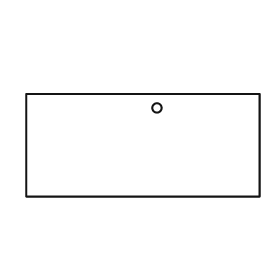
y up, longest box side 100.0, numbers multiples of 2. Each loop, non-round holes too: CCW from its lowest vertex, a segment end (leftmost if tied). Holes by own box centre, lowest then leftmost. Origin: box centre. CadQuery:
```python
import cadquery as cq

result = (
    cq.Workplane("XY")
    .moveTo(-50.0, -22.0)
    .lineTo(50.0, -22.0)
    .lineTo(50.0, 22.0)
    .lineTo(-50.0, 22.0)
    .close()
    .moveTo(6.0, 16.0)
    .circle(2.0)
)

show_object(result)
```